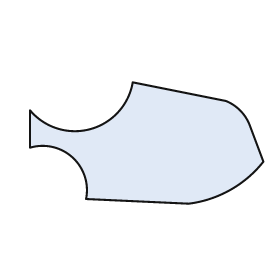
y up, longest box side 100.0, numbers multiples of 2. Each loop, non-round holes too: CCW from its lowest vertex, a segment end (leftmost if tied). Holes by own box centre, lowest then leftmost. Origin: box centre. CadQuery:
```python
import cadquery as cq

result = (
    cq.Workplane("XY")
    .moveTo(18.0, -26.0)
    .threePointArc((36.0, -20.0), (50.0, -8.0))
    .lineTo(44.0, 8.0)
    .threePointArc((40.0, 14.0), (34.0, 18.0))
    .lineTo(-6.0, 26.0)
    .threePointArc((-24.0, 6.0), (-50.0, 14.0))
    .lineTo(-50.0, -2.0)
    .threePointArc((-32.0, -6.0), (-26.0, -24.0))
    .close()
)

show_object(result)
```